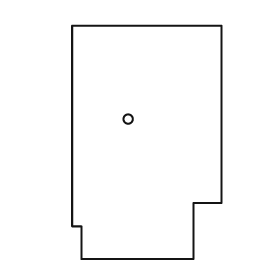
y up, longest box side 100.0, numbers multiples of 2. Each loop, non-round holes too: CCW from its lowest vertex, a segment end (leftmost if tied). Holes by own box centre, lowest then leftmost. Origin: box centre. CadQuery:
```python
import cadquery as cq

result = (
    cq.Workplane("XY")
    .moveTo(-28.0, -50.0)
    .lineTo(20.0, -50.0)
    .lineTo(20.0, -26.0)
    .lineTo(32.0, -26.0)
    .lineTo(32.0, 50.0)
    .lineTo(-32.0, 50.0)
    .lineTo(-32.0, -36.0)
    .lineTo(-28.0, -36.0)
    .close()
    .moveTo(-8.0, 10.0)
    .circle(2.0)
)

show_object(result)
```